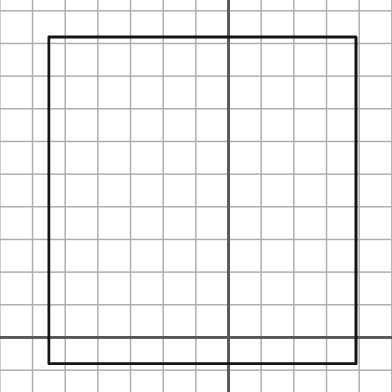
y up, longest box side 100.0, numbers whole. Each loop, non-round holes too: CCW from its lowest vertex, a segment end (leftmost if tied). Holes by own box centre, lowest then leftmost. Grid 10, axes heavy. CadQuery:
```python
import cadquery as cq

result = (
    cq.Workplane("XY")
    .moveTo(-55.0, -8.0)
    .lineTo(39.0, -8.0)
    .lineTo(39.0, 92.0)
    .lineTo(-55.0, 92.0)
    .close()
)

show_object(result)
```